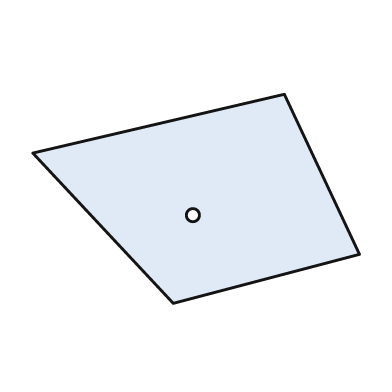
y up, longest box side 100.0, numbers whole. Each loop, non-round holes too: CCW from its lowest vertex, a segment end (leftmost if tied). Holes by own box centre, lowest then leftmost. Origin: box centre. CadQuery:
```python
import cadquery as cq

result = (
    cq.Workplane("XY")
    .moveTo(-7.0, -32.0)
    .lineTo(50.0, -17.0)
    .lineTo(27.0, 32.0)
    .lineTo(-50.0, 14.0)
    .close()
    .moveTo(-1.0, -5.0)
    .circle(2.0)
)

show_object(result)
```